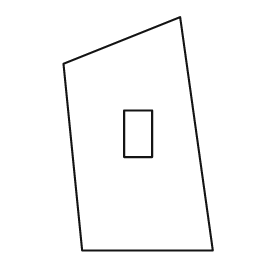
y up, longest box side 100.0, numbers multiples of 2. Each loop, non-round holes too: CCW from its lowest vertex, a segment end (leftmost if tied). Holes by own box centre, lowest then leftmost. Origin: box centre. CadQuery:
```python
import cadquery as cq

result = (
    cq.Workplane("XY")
    .moveTo(-24.0, -50.0)
    .lineTo(32.0, -50.0)
    .lineTo(18.0, 50.0)
    .lineTo(-32.0, 30.0)
    .close()
    .moveTo(-6.0, -10.0)
    .lineTo(6.0, -10.0)
    .lineTo(6.0, 10.0)
    .lineTo(-6.0, 10.0)
    .close()
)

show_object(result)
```